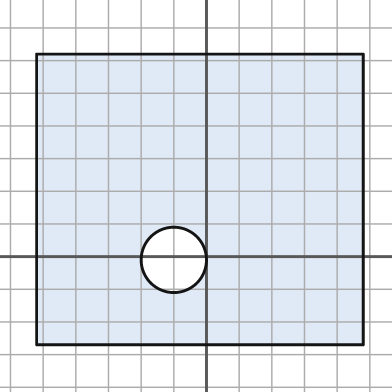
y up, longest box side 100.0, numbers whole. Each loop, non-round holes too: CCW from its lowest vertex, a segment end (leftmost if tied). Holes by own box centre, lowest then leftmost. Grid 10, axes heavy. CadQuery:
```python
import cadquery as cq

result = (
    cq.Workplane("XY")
    .moveTo(-52.0, -27.0)
    .lineTo(48.0, -27.0)
    .lineTo(48.0, 62.0)
    .lineTo(-52.0, 62.0)
    .close()
    .moveTo(-10.0, -1.0)
    .circle(10.0)
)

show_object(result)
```